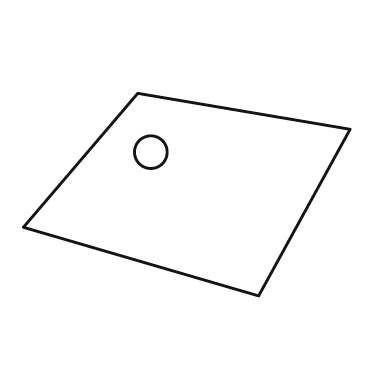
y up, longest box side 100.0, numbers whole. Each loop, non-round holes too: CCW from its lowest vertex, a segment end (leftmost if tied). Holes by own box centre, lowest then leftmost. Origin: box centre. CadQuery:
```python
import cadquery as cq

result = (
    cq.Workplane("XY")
    .moveTo(22.0, -31.0)
    .lineTo(50.0, 20.0)
    .lineTo(-15.0, 31.0)
    .lineTo(-50.0, -10.0)
    .close()
    .moveTo(-11.0, 13.0)
    .circle(5.0)
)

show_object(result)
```